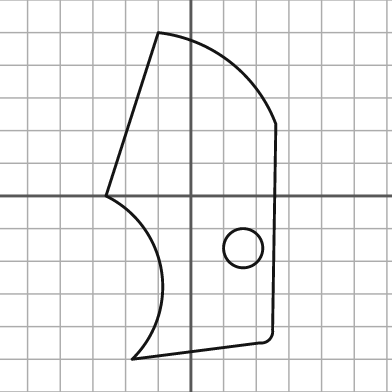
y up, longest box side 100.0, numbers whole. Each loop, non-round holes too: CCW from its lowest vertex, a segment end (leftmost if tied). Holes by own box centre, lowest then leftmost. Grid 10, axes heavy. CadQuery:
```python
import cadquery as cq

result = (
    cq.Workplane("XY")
    .moveTo(-18.0, -50.0)
    .lineTo(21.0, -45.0)
    .threePointArc((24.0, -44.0), (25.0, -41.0))
    .lineTo(26.0, 22.0)
    .threePointArc((12.0, 41.0), (-10.0, 50.0))
    .lineTo(-26.0, 0.0)
    .threePointArc((-9.0, -23.0), (-18.0, -50.0))
    .close()
    .moveTo(16.0, -16.0)
    .circle(6.0)
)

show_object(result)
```